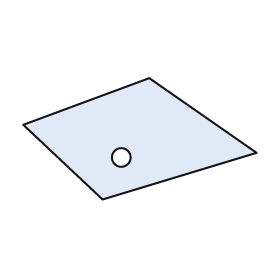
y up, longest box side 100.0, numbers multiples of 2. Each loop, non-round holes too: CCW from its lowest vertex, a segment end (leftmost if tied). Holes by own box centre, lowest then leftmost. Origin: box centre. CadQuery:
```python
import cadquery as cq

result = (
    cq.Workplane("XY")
    .moveTo(-16.0, -26.0)
    .lineTo(50.0, -6.0)
    .lineTo(4.0, 26.0)
    .lineTo(-50.0, 6.0)
    .close()
    .moveTo(-8.0, -8.0)
    .circle(4.0)
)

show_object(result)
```